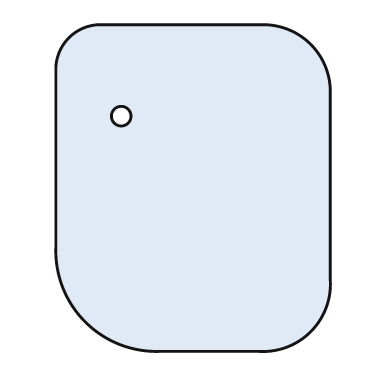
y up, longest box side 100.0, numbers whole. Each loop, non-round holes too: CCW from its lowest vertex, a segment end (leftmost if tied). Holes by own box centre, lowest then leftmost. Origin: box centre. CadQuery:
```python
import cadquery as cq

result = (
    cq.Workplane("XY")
    .moveTo(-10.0, -50.0)
    .lineTo(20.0, -50.0)
    .threePointArc((36.0, -44.0), (42.0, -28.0))
    .lineTo(42.0, 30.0)
    .threePointArc((36.0, 44.0), (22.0, 50.0))
    .lineTo(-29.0, 50.0)
    .threePointArc((-38.0, 46.0), (-42.0, 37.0))
    .lineTo(-42.0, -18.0)
    .threePointArc((-33.0, -41.0), (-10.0, -50.0))
    .close()
    .moveTo(-22.0, 22.0)
    .circle(3.0)
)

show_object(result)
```